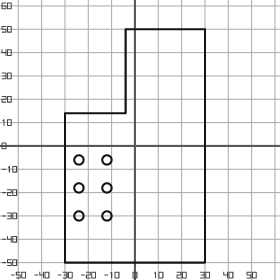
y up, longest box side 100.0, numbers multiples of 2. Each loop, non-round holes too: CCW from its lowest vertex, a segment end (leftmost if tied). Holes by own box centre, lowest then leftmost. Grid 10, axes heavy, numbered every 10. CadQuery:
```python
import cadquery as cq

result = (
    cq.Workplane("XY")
    .moveTo(-30.0, -50.0)
    .lineTo(30.0, -50.0)
    .lineTo(30.0, 50.0)
    .lineTo(-4.0, 50.0)
    .lineTo(-4.0, 14.0)
    .lineTo(-30.0, 14.0)
    .close()
    .moveTo(-24.0, -30.0)
    .circle(2.0)
    .moveTo(-12.0, -30.0)
    .circle(2.0)
    .moveTo(-24.0, -18.0)
    .circle(2.0)
    .moveTo(-12.0, -18.0)
    .circle(2.0)
    .moveTo(-24.0, -6.0)
    .circle(2.0)
    .moveTo(-12.0, -6.0)
    .circle(2.0)
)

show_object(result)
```